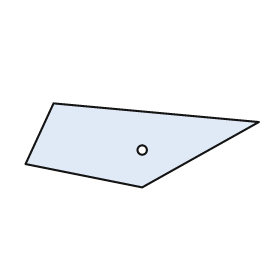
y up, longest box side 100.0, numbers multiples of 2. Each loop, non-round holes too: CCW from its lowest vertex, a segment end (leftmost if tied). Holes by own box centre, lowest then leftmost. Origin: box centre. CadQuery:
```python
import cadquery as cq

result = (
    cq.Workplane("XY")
    .moveTo(0.0, -18.0)
    .lineTo(50.0, 10.0)
    .lineTo(-38.0, 18.0)
    .lineTo(-50.0, -8.0)
    .close()
    .moveTo(0.0, -2.0)
    .circle(2.0)
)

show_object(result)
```